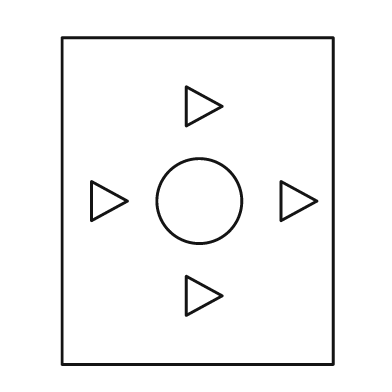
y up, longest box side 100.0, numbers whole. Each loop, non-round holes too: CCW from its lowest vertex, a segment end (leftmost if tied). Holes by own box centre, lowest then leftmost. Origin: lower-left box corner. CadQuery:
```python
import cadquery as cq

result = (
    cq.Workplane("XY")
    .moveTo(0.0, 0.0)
    .lineTo(83.0, 0.0)
    .lineTo(83.0, 100.0)
    .lineTo(0.0, 100.0)
    .close()
    .moveTo(38.0, 15.0)
    .lineTo(49.0, 21.0)
    .lineTo(38.0, 27.0)
    .close()
    .moveTo(9.0, 44.0)
    .lineTo(20.0, 50.0)
    .lineTo(9.0, 56.0)
    .close()
    .moveTo(42.0, 50.0)
    .circle(13.0)
    .moveTo(67.0, 44.0)
    .lineTo(78.0, 50.0)
    .lineTo(67.0, 56.0)
    .close()
    .moveTo(38.0, 73.0)
    .lineTo(49.0, 79.0)
    .lineTo(38.0, 85.0)
    .close()
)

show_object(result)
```